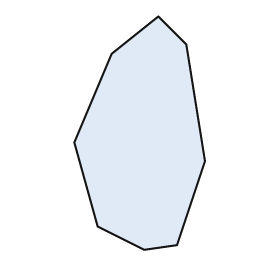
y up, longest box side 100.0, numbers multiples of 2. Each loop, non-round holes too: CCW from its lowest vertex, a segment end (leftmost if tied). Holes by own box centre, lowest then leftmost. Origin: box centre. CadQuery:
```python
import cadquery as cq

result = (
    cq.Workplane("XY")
    .moveTo(2.0, -50.0)
    .lineTo(16.0, -48.0)
    .lineTo(28.0, -12.0)
    .lineTo(20.0, 38.0)
    .lineTo(8.0, 50.0)
    .lineTo(-12.0, 34.0)
    .lineTo(-28.0, -4.0)
    .lineTo(-18.0, -40.0)
    .close()
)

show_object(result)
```